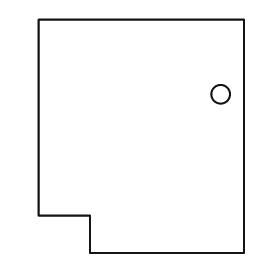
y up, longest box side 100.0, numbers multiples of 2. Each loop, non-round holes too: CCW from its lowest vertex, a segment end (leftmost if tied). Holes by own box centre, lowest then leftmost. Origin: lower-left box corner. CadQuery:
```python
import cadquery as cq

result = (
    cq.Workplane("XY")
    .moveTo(22.0, 0.0)
    .lineTo(88.0, 0.0)
    .lineTo(88.0, 100.0)
    .lineTo(0.0, 100.0)
    .lineTo(0.0, 16.0)
    .lineTo(22.0, 16.0)
    .close()
    .moveTo(78.0, 68.0)
    .circle(4.0)
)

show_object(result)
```